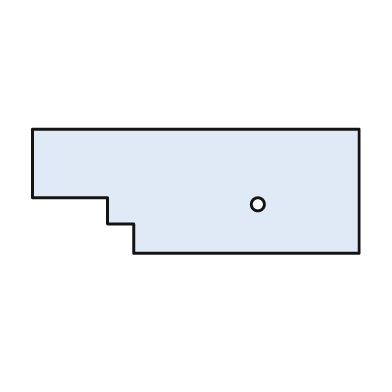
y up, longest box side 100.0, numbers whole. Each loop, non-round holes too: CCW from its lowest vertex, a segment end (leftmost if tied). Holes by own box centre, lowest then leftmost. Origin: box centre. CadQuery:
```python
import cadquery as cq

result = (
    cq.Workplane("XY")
    .moveTo(-19.0, -19.0)
    .lineTo(50.0, -19.0)
    .lineTo(50.0, 19.0)
    .lineTo(-50.0, 19.0)
    .lineTo(-50.0, -2.0)
    .lineTo(-27.0, -2.0)
    .lineTo(-27.0, -10.0)
    .lineTo(-19.0, -10.0)
    .close()
    .moveTo(19.0, -4.0)
    .circle(2.0)
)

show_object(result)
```